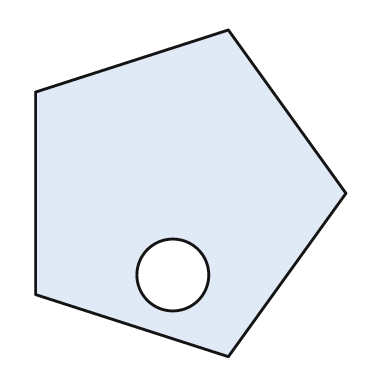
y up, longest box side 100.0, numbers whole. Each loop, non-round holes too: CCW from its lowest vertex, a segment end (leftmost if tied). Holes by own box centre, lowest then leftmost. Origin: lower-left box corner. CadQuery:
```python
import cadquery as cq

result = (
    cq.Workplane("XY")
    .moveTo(59.0, 0.0)
    .lineTo(95.0, 50.0)
    .lineTo(59.0, 100.0)
    .lineTo(0.0, 81.0)
    .lineTo(0.0, 19.0)
    .close()
    .moveTo(42.0, 25.0)
    .circle(11.0)
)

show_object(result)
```